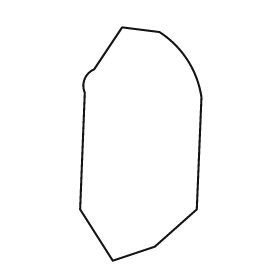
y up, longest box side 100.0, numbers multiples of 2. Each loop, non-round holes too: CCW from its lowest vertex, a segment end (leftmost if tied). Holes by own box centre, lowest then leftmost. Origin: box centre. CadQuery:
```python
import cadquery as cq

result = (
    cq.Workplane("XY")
    .moveTo(-12.0, -50.0)
    .lineTo(6.0, -44.0)
    .lineTo(24.0, -28.0)
    .lineTo(26.0, 20.0)
    .threePointArc((20.0, 36.0), (8.0, 48.0))
    .lineTo(-8.0, 50.0)
    .lineTo(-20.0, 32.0)
    .threePointArc((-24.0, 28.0), (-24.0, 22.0))
    .lineTo(-26.0, -28.0)
    .close()
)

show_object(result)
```